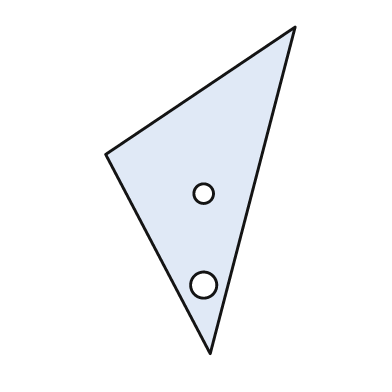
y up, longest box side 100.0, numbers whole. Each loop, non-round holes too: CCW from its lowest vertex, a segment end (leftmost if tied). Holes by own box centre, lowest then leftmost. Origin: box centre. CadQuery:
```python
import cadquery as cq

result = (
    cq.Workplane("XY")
    .moveTo(3.0, -50.0)
    .lineTo(29.0, 50.0)
    .lineTo(-29.0, 11.0)
    .close()
    .moveTo(1.0, -29.0)
    .circle(4.0)
    .moveTo(1.0, -1.0)
    .circle(3.0)
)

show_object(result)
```